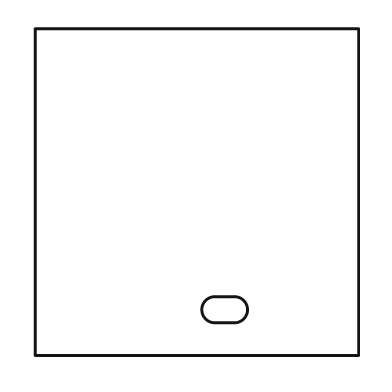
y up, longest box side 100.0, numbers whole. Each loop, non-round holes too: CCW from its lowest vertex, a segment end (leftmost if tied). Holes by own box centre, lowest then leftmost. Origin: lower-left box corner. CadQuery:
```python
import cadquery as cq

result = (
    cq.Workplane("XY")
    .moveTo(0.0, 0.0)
    .lineTo(99.0, 0.0)
    .lineTo(99.0, 100.0)
    .lineTo(0.0, 100.0)
    .close()
    .moveTo(55.0, 10.0)
    .lineTo(61.0, 10.0)
    .threePointArc((65.0, 14.0), (61.0, 18.0))
    .lineTo(55.0, 18.0)
    .threePointArc((51.0, 14.0), (55.0, 10.0))
    .close()
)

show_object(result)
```